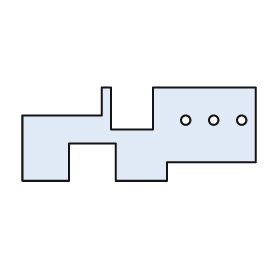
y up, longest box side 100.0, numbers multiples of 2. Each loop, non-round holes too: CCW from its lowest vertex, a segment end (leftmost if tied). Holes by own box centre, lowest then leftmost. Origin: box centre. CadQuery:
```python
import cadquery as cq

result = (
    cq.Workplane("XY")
    .moveTo(-50.0, -20.0)
    .lineTo(-30.0, -20.0)
    .lineTo(-30.0, -4.0)
    .lineTo(-10.0, -4.0)
    .lineTo(-10.0, -20.0)
    .lineTo(12.0, -20.0)
    .lineTo(12.0, -12.0)
    .lineTo(50.0, -12.0)
    .lineTo(50.0, 20.0)
    .lineTo(6.0, 20.0)
    .lineTo(6.0, 2.0)
    .lineTo(-12.0, 2.0)
    .lineTo(-12.0, 20.0)
    .lineTo(-16.0, 20.0)
    .lineTo(-16.0, 8.0)
    .lineTo(-50.0, 8.0)
    .close()
    .moveTo(20.0, 6.0)
    .circle(2.0)
    .moveTo(32.0, 6.0)
    .circle(2.0)
    .moveTo(44.0, 6.0)
    .circle(2.0)
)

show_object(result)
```